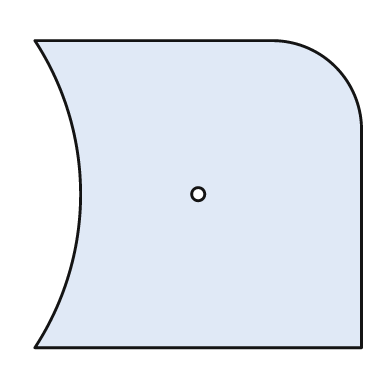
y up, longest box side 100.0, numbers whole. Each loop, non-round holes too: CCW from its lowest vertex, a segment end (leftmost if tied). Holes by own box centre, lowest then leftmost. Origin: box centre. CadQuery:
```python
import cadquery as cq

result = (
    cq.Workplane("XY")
    .moveTo(-50.0, -47.0)
    .lineTo(50.0, -47.0)
    .lineTo(50.0, 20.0)
    .threePointArc((42.0, 39.0), (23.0, 47.0))
    .lineTo(-50.0, 47.0)
    .threePointArc((-36.0, 0.0), (-50.0, -47.0))
    .close()
    .moveTo(0.0, 0.0)
    .circle(2.0)
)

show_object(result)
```